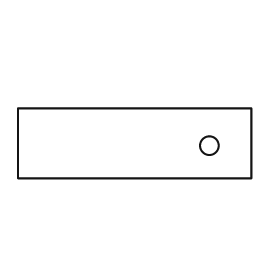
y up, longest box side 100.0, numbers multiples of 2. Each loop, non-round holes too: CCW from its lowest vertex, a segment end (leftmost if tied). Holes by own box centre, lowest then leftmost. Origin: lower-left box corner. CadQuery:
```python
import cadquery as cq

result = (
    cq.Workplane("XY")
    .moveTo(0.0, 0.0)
    .lineTo(100.0, 0.0)
    .lineTo(100.0, 30.0)
    .lineTo(0.0, 30.0)
    .close()
    .moveTo(82.0, 14.0)
    .circle(4.0)
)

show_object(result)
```